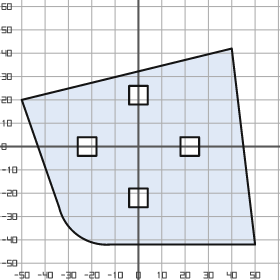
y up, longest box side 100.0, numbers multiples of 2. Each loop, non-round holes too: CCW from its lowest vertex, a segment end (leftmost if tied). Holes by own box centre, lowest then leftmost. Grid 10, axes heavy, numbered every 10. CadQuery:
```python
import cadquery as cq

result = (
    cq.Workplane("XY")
    .moveTo(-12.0, -42.0)
    .lineTo(50.0, -42.0)
    .lineTo(40.0, 42.0)
    .lineTo(-50.0, 20.0)
    .lineTo(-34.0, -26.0)
    .threePointArc((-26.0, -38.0), (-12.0, -42.0))
    .close()
    .moveTo(-4.0, -26.0)
    .lineTo(4.0, -26.0)
    .lineTo(4.0, -18.0)
    .lineTo(-4.0, -18.0)
    .close()
    .moveTo(-26.0, -4.0)
    .lineTo(-18.0, -4.0)
    .lineTo(-18.0, 4.0)
    .lineTo(-26.0, 4.0)
    .close()
    .moveTo(18.0, -4.0)
    .lineTo(26.0, -4.0)
    .lineTo(26.0, 4.0)
    .lineTo(18.0, 4.0)
    .close()
    .moveTo(-4.0, 18.0)
    .lineTo(4.0, 18.0)
    .lineTo(4.0, 26.0)
    .lineTo(-4.0, 26.0)
    .close()
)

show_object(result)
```